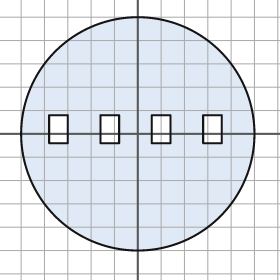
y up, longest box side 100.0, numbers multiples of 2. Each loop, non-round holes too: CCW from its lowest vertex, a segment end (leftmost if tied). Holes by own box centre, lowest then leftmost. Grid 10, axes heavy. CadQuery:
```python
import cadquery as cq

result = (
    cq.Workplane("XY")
    .moveTo(0.0, 0.0)
    .circle(50.0)
    .moveTo(-38.0, -4.0)
    .lineTo(-30.0, -4.0)
    .lineTo(-30.0, 8.0)
    .lineTo(-38.0, 8.0)
    .close()
    .moveTo(-16.0, -4.0)
    .lineTo(-8.0, -4.0)
    .lineTo(-8.0, 8.0)
    .lineTo(-16.0, 8.0)
    .close()
    .moveTo(6.0, -4.0)
    .lineTo(14.0, -4.0)
    .lineTo(14.0, 8.0)
    .lineTo(6.0, 8.0)
    .close()
    .moveTo(28.0, -4.0)
    .lineTo(36.0, -4.0)
    .lineTo(36.0, 8.0)
    .lineTo(28.0, 8.0)
    .close()
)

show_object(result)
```